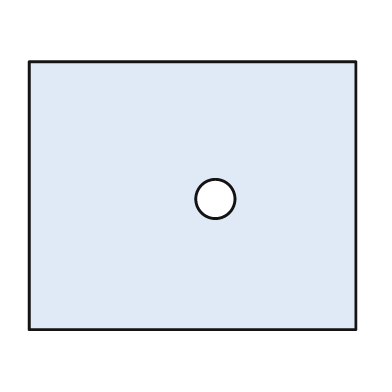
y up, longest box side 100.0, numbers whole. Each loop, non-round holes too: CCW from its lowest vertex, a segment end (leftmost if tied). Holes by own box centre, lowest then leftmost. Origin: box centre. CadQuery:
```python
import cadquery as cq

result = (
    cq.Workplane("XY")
    .moveTo(-50.0, -41.0)
    .lineTo(50.0, -41.0)
    .lineTo(50.0, 41.0)
    .lineTo(-50.0, 41.0)
    .close()
    .moveTo(7.0, -1.0)
    .circle(6.0)
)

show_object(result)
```